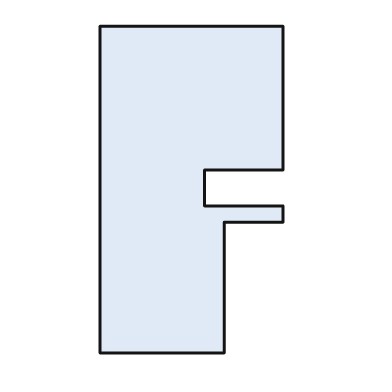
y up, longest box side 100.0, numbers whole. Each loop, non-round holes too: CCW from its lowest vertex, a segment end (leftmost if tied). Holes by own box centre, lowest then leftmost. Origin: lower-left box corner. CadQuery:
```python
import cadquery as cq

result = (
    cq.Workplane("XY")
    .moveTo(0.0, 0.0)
    .lineTo(38.0, 0.0)
    .lineTo(38.0, 40.0)
    .lineTo(56.0, 40.0)
    .lineTo(56.0, 45.0)
    .lineTo(32.0, 45.0)
    .lineTo(32.0, 56.0)
    .lineTo(56.0, 56.0)
    .lineTo(56.0, 100.0)
    .lineTo(0.0, 100.0)
    .close()
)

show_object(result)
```